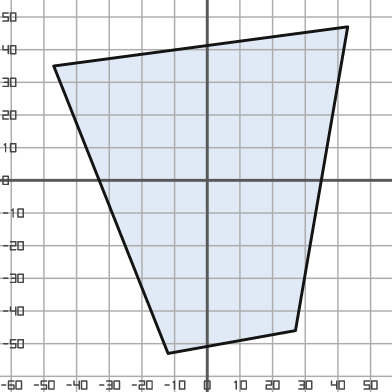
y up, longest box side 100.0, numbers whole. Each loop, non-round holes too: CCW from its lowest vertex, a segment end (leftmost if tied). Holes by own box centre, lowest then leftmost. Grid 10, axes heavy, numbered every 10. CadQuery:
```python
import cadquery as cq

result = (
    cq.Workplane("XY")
    .moveTo(-12.0, -53.0)
    .lineTo(27.0, -46.0)
    .lineTo(43.0, 47.0)
    .lineTo(-47.0, 35.0)
    .close()
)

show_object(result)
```